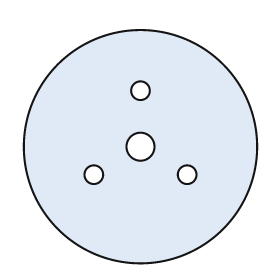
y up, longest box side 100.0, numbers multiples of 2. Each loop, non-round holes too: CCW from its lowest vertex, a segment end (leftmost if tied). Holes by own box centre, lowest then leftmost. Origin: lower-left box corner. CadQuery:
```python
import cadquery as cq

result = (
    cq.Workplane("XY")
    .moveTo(50.0, 50.0)
    .circle(50.0)
    .moveTo(30.0, 38.0)
    .circle(4.0)
    .moveTo(70.0, 38.0)
    .circle(4.0)
    .moveTo(50.0, 50.0)
    .circle(6.0)
    .moveTo(50.0, 74.0)
    .circle(4.0)
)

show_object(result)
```